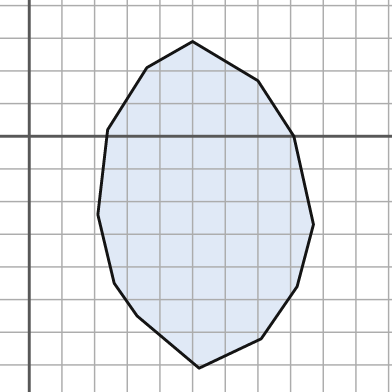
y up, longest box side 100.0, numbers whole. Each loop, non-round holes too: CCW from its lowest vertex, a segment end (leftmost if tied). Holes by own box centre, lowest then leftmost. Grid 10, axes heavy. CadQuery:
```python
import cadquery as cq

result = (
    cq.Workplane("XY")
    .moveTo(52.0, -71.0)
    .lineTo(71.0, -62.0)
    .lineTo(82.0, -46.0)
    .lineTo(87.0, -27.0)
    .lineTo(81.0, 0.0)
    .lineTo(70.0, 17.0)
    .lineTo(50.0, 29.0)
    .lineTo(36.0, 21.0)
    .lineTo(24.0, 2.0)
    .lineTo(21.0, -24.0)
    .lineTo(26.0, -45.0)
    .lineTo(33.0, -55.0)
    .close()
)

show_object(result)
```